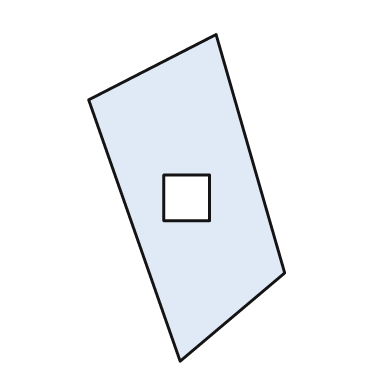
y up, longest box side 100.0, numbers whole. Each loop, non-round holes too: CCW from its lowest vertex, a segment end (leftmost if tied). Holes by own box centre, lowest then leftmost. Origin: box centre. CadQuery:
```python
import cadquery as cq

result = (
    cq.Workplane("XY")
    .moveTo(-2.0, -50.0)
    .lineTo(30.0, -23.0)
    .lineTo(9.0, 50.0)
    .lineTo(-30.0, 30.0)
    .close()
    .moveTo(-7.0, -7.0)
    .lineTo(7.0, -7.0)
    .lineTo(7.0, 7.0)
    .lineTo(-7.0, 7.0)
    .close()
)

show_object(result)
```